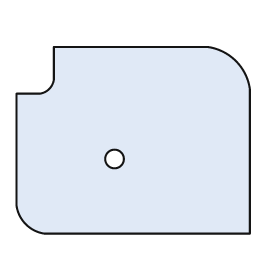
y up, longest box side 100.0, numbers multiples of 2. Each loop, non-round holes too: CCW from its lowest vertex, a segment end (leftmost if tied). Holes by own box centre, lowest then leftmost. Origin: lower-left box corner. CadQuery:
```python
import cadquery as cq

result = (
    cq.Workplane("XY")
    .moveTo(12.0, 0.0)
    .lineTo(100.0, 0.0)
    .lineTo(100.0, 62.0)
    .threePointArc((94.0, 74.0), (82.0, 80.0))
    .lineTo(16.0, 80.0)
    .lineTo(16.0, 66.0)
    .threePointArc((14.0, 62.0), (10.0, 60.0))
    .lineTo(0.0, 60.0)
    .lineTo(0.0, 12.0)
    .threePointArc((4.0, 4.0), (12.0, 0.0))
    .close()
    .moveTo(42.0, 32.0)
    .circle(4.0)
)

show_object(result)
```